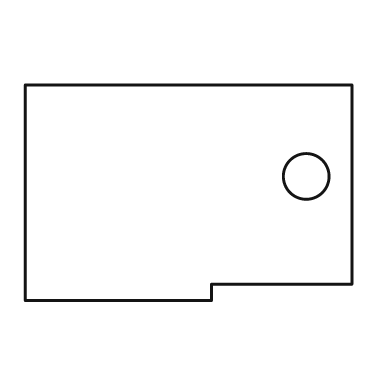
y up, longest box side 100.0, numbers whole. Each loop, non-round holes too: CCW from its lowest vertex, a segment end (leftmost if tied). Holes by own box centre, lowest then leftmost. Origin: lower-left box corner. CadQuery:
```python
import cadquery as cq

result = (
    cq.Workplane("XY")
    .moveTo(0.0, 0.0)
    .lineTo(57.0, 0.0)
    .lineTo(57.0, 5.0)
    .lineTo(100.0, 5.0)
    .lineTo(100.0, 66.0)
    .lineTo(0.0, 66.0)
    .close()
    .moveTo(86.0, 38.0)
    .circle(7.0)
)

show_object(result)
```